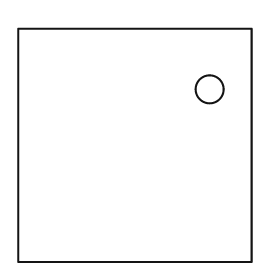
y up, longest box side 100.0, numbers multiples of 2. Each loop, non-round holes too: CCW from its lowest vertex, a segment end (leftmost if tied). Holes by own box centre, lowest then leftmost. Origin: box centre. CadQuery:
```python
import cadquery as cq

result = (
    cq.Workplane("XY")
    .moveTo(-50.0, -50.0)
    .lineTo(50.0, -50.0)
    .lineTo(50.0, 50.0)
    .lineTo(-50.0, 50.0)
    .close()
    .moveTo(32.0, 24.0)
    .circle(6.0)
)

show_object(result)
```